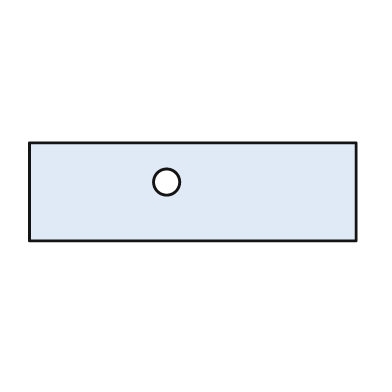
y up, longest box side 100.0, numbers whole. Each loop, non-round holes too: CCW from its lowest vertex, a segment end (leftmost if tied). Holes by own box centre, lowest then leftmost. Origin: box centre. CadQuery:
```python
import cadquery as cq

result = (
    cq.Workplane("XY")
    .moveTo(-50.0, -15.0)
    .lineTo(50.0, -15.0)
    .lineTo(50.0, 15.0)
    .lineTo(-50.0, 15.0)
    .close()
    .moveTo(-8.0, 3.0)
    .circle(4.0)
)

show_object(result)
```